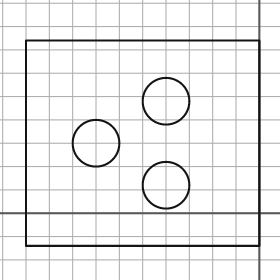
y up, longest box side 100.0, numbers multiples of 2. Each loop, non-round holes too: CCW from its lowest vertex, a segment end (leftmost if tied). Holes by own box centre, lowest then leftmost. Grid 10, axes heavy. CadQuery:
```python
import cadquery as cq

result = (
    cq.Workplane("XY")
    .moveTo(-100.0, -14.0)
    .lineTo(0.0, -14.0)
    .lineTo(0.0, 74.0)
    .lineTo(-100.0, 74.0)
    .close()
    .moveTo(-40.0, 12.0)
    .circle(10.0)
    .moveTo(-70.0, 30.0)
    .circle(10.0)
    .moveTo(-40.0, 48.0)
    .circle(10.0)
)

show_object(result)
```